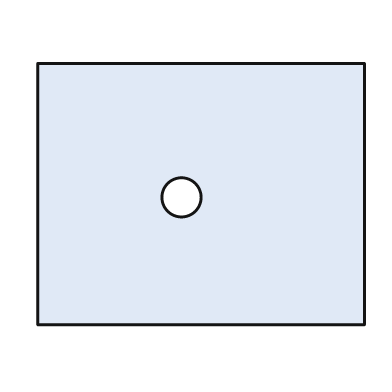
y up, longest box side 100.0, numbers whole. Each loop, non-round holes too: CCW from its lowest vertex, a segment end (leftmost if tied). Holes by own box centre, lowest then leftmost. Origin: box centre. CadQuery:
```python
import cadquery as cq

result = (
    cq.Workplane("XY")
    .moveTo(-50.0, -40.0)
    .lineTo(50.0, -40.0)
    .lineTo(50.0, 40.0)
    .lineTo(-50.0, 40.0)
    .close()
    .moveTo(-6.0, -1.0)
    .circle(6.0)
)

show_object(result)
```